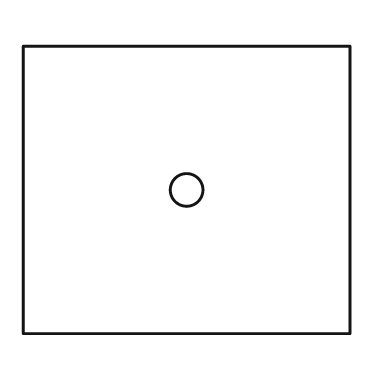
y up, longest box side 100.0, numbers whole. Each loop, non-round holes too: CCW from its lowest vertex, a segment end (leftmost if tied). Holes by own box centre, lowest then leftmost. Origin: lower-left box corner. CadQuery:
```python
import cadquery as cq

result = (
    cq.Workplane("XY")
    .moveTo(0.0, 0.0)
    .lineTo(100.0, 0.0)
    .lineTo(100.0, 88.0)
    .lineTo(0.0, 88.0)
    .close()
    .moveTo(50.0, 44.0)
    .circle(5.0)
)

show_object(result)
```